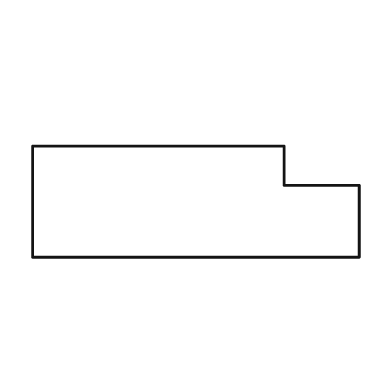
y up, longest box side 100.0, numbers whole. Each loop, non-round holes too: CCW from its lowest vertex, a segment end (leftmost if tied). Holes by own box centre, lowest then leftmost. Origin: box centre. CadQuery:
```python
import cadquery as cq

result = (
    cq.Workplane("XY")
    .moveTo(-50.0, -17.0)
    .lineTo(50.0, -17.0)
    .lineTo(50.0, 5.0)
    .lineTo(27.0, 5.0)
    .lineTo(27.0, 17.0)
    .lineTo(-50.0, 17.0)
    .close()
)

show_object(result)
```